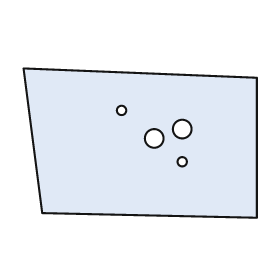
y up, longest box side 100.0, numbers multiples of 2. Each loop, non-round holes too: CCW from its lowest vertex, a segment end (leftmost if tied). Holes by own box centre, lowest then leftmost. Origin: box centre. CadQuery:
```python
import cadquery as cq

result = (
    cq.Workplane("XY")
    .moveTo(50.0, -32.0)
    .lineTo(50.0, 28.0)
    .lineTo(-50.0, 32.0)
    .lineTo(-42.0, -30.0)
    .close()
    .moveTo(18.0, -8.0)
    .circle(2.0)
    .moveTo(6.0, 2.0)
    .circle(4.0)
    .moveTo(18.0, 6.0)
    .circle(4.0)
    .moveTo(-8.0, 14.0)
    .circle(2.0)
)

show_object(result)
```